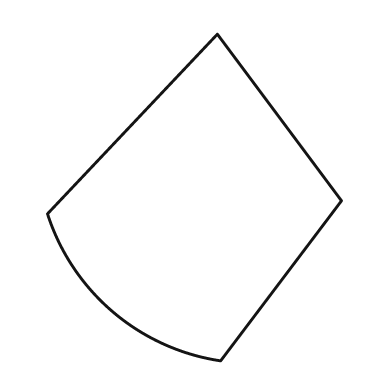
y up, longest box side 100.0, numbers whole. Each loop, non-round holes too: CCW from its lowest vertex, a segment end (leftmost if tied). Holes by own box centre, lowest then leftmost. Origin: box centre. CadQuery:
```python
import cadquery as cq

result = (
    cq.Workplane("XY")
    .moveTo(8.0, -50.0)
    .lineTo(45.0, -1.0)
    .lineTo(7.0, 50.0)
    .lineTo(-45.0, -5.0)
    .threePointArc((-25.0, -35.0), (8.0, -50.0))
    .close()
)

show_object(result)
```